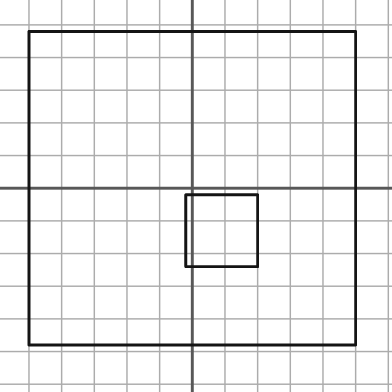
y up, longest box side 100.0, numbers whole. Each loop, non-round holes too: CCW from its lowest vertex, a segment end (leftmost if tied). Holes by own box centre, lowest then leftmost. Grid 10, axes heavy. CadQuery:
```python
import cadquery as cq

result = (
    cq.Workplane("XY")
    .moveTo(-50.0, -48.0)
    .lineTo(50.0, -48.0)
    .lineTo(50.0, 48.0)
    .lineTo(-50.0, 48.0)
    .close()
    .moveTo(-2.0, -24.0)
    .lineTo(20.0, -24.0)
    .lineTo(20.0, -2.0)
    .lineTo(-2.0, -2.0)
    .close()
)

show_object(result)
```